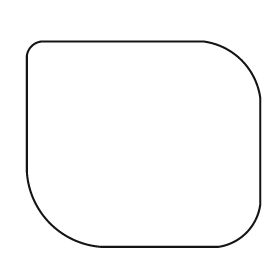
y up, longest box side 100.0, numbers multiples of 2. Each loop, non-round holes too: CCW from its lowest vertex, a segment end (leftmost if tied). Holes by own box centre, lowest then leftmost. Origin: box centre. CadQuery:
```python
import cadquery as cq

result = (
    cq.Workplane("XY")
    .moveTo(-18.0, -44.0)
    .lineTo(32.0, -44.0)
    .threePointArc((44.0, -38.0), (50.0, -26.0))
    .lineTo(50.0, 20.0)
    .threePointArc((42.0, 36.0), (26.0, 44.0))
    .lineTo(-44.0, 44.0)
    .threePointArc((-48.0, 42.0), (-50.0, 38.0))
    .lineTo(-50.0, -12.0)
    .threePointArc((-40.0, -34.0), (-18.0, -44.0))
    .close()
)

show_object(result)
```